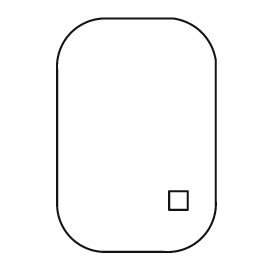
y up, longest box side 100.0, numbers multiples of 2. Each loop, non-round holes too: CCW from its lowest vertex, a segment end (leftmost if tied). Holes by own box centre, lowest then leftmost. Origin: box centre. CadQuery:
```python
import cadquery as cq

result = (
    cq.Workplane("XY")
    .moveTo(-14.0, -50.0)
    .lineTo(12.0, -50.0)
    .threePointArc((28.0, -44.0), (34.0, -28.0))
    .lineTo(34.0, 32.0)
    .threePointArc((28.0, 44.0), (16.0, 50.0))
    .lineTo(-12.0, 50.0)
    .threePointArc((-28.0, 44.0), (-34.0, 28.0))
    .lineTo(-34.0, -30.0)
    .threePointArc((-28.0, -44.0), (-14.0, -50.0))
    .close()
    .moveTo(14.0, -32.0)
    .lineTo(22.0, -32.0)
    .lineTo(22.0, -24.0)
    .lineTo(14.0, -24.0)
    .close()
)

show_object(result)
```